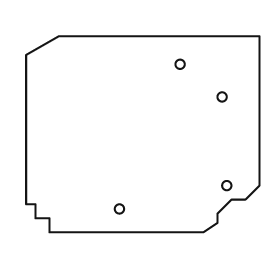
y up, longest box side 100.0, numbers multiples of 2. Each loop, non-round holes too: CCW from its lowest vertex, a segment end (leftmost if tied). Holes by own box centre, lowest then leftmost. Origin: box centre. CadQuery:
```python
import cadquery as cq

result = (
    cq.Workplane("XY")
    .moveTo(-40.0, -42.0)
    .lineTo(26.0, -42.0)
    .lineTo(32.0, -38.0)
    .lineTo(32.0, -34.0)
    .lineTo(38.0, -28.0)
    .lineTo(44.0, -28.0)
    .lineTo(50.0, -22.0)
    .lineTo(50.0, 42.0)
    .lineTo(-36.0, 42.0)
    .lineTo(-50.0, 34.0)
    .lineTo(-50.0, -30.0)
    .lineTo(-46.0, -30.0)
    .lineTo(-46.0, -36.0)
    .lineTo(-40.0, -36.0)
    .close()
    .moveTo(-10.0, -32.0)
    .circle(2.0)
    .moveTo(36.0, -22.0)
    .circle(2.0)
    .moveTo(34.0, 16.0)
    .circle(2.0)
    .moveTo(16.0, 30.0)
    .circle(2.0)
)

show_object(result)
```